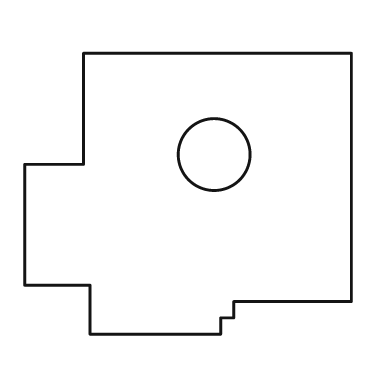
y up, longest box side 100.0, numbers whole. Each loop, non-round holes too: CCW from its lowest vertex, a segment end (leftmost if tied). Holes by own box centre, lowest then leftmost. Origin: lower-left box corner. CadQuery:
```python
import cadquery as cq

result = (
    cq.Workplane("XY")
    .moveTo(20.0, 0.0)
    .lineTo(60.0, 0.0)
    .lineTo(60.0, 5.0)
    .lineTo(64.0, 5.0)
    .lineTo(64.0, 10.0)
    .lineTo(100.0, 10.0)
    .lineTo(100.0, 86.0)
    .lineTo(18.0, 86.0)
    .lineTo(18.0, 52.0)
    .lineTo(0.0, 52.0)
    .lineTo(0.0, 15.0)
    .lineTo(20.0, 15.0)
    .close()
    .moveTo(58.0, 55.0)
    .circle(11.0)
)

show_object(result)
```